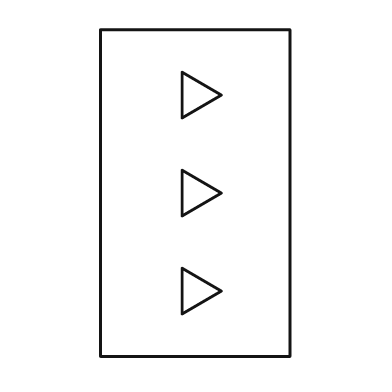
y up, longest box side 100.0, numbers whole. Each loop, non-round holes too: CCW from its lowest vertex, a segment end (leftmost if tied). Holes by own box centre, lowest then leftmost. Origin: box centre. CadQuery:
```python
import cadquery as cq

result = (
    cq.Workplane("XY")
    .moveTo(-29.0, -50.0)
    .lineTo(29.0, -50.0)
    .lineTo(29.0, 50.0)
    .lineTo(-29.0, 50.0)
    .close()
    .moveTo(-4.0, -37.0)
    .lineTo(8.0, -30.0)
    .lineTo(-4.0, -23.0)
    .close()
    .moveTo(-4.0, -7.0)
    .lineTo(8.0, 0.0)
    .lineTo(-4.0, 7.0)
    .close()
    .moveTo(-4.0, 23.0)
    .lineTo(8.0, 30.0)
    .lineTo(-4.0, 37.0)
    .close()
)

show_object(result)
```